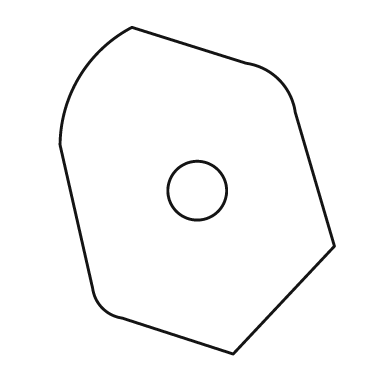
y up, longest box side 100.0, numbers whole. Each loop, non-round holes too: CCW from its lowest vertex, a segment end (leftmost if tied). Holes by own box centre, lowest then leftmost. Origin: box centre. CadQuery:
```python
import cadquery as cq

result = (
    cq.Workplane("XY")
    .moveTo(11.0, -50.0)
    .lineTo(42.0, -17.0)
    .lineTo(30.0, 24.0)
    .threePointArc((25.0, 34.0), (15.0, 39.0))
    .lineTo(-20.0, 50.0)
    .threePointArc((-36.0, 35.0), (-42.0, 14.0))
    .lineTo(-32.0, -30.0)
    .threePointArc((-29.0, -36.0), (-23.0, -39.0))
    .close()
    .moveTo(0.0, 0.0)
    .circle(9.0)
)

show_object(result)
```